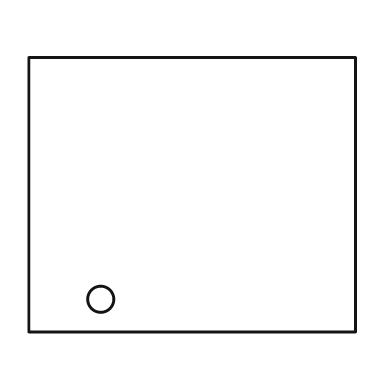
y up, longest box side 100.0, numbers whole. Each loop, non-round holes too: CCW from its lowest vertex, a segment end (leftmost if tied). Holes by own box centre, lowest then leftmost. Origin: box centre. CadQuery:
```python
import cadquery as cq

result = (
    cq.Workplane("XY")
    .moveTo(-50.0, -42.0)
    .lineTo(50.0, -42.0)
    .lineTo(50.0, 42.0)
    .lineTo(-50.0, 42.0)
    .close()
    .moveTo(-28.0, -32.0)
    .circle(4.0)
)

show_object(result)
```